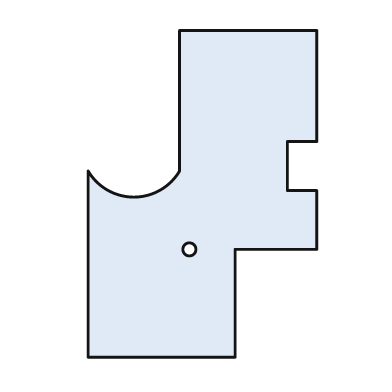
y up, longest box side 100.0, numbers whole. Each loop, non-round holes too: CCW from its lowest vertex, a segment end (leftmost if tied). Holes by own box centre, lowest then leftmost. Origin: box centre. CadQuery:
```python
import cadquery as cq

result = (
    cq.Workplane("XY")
    .moveTo(-35.0, -50.0)
    .lineTo(10.0, -50.0)
    .lineTo(10.0, -17.0)
    .lineTo(35.0, -17.0)
    .lineTo(35.0, 1.0)
    .lineTo(26.0, 1.0)
    .lineTo(26.0, 16.0)
    .lineTo(35.0, 16.0)
    .lineTo(35.0, 50.0)
    .lineTo(-7.0, 50.0)
    .lineTo(-7.0, 7.0)
    .threePointArc((-21.0, -1.0), (-35.0, 7.0))
    .close()
    .moveTo(-4.0, -17.0)
    .circle(2.0)
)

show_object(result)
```